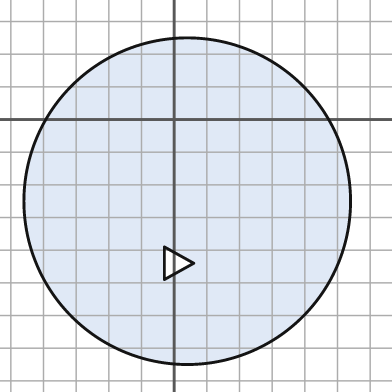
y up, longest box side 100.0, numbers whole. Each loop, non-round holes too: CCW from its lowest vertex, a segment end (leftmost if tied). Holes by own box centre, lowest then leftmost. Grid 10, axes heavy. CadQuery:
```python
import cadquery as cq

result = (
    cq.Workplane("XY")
    .moveTo(4.0, -25.0)
    .circle(50.0)
    .moveTo(-3.0, -49.0)
    .lineTo(6.0, -44.0)
    .lineTo(-3.0, -39.0)
    .close()
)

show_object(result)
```